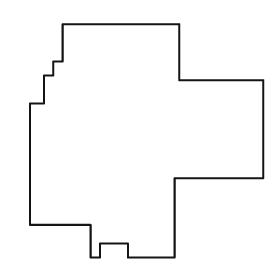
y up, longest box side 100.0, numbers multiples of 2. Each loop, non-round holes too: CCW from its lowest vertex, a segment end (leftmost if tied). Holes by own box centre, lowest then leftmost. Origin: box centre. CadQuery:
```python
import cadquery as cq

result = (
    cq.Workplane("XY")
    .moveTo(-24.0, -50.0)
    .lineTo(-20.0, -50.0)
    .lineTo(-20.0, -44.0)
    .lineTo(-8.0, -44.0)
    .lineTo(-8.0, -50.0)
    .lineTo(12.0, -50.0)
    .lineTo(12.0, -16.0)
    .lineTo(50.0, -16.0)
    .lineTo(50.0, 26.0)
    .lineTo(14.0, 26.0)
    .lineTo(14.0, 50.0)
    .lineTo(-36.0, 50.0)
    .lineTo(-36.0, 34.0)
    .lineTo(-40.0, 34.0)
    .lineTo(-40.0, 28.0)
    .lineTo(-44.0, 28.0)
    .lineTo(-44.0, 16.0)
    .lineTo(-50.0, 16.0)
    .lineTo(-50.0, -36.0)
    .lineTo(-24.0, -36.0)
    .close()
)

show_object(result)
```